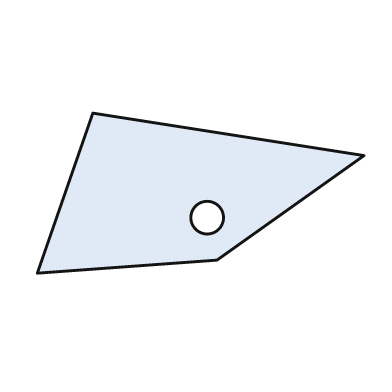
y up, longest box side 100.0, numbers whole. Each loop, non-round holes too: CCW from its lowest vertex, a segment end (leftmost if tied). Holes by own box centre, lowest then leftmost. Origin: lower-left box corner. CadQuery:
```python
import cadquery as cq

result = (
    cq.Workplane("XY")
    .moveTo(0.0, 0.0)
    .lineTo(55.0, 4.0)
    .lineTo(100.0, 36.0)
    .lineTo(17.0, 49.0)
    .close()
    .moveTo(52.0, 17.0)
    .circle(5.0)
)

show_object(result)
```